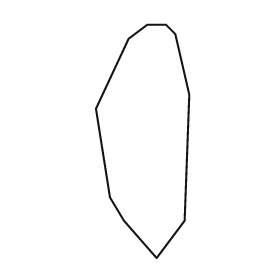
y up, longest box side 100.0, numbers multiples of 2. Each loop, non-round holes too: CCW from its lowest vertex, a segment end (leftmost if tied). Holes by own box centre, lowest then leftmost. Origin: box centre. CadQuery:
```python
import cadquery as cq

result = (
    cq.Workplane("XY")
    .moveTo(6.0, -50.0)
    .lineTo(18.0, -34.0)
    .lineTo(20.0, 20.0)
    .lineTo(14.0, 46.0)
    .lineTo(10.0, 50.0)
    .lineTo(2.0, 50.0)
    .lineTo(-6.0, 44.0)
    .lineTo(-20.0, 14.0)
    .lineTo(-14.0, -24.0)
    .lineTo(-8.0, -34.0)
    .close()
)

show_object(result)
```